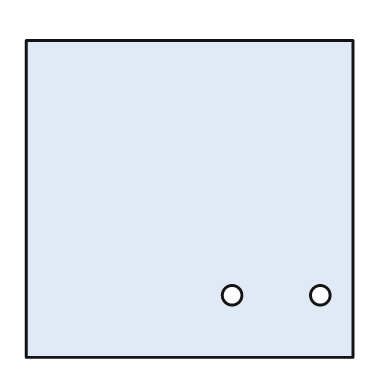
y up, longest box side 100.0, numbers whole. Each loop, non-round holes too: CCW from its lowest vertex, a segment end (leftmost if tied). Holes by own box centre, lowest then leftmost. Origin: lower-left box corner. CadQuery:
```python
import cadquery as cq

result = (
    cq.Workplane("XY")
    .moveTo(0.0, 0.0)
    .lineTo(100.0, 0.0)
    .lineTo(100.0, 97.0)
    .lineTo(0.0, 97.0)
    .close()
    .moveTo(63.0, 19.0)
    .circle(3.0)
    .moveTo(90.0, 19.0)
    .circle(3.0)
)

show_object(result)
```